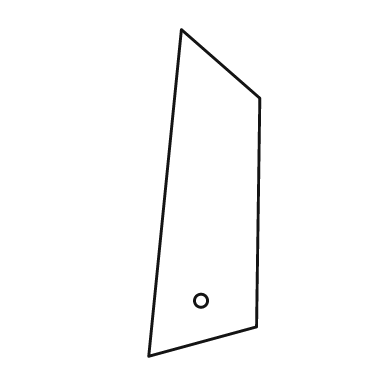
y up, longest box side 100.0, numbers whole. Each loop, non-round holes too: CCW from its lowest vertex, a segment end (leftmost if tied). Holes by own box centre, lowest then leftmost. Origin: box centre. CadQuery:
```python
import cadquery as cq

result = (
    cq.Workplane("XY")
    .moveTo(-17.0, -50.0)
    .lineTo(16.0, -41.0)
    .lineTo(17.0, 29.0)
    .lineTo(-7.0, 50.0)
    .close()
    .moveTo(-1.0, -33.0)
    .circle(2.0)
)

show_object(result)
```